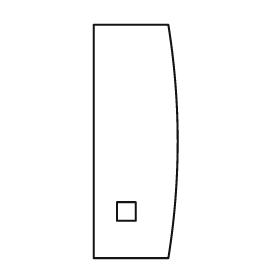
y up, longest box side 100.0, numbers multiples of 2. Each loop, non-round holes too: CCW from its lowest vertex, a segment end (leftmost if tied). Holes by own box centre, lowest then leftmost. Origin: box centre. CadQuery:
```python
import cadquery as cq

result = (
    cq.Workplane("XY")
    .moveTo(-18.0, -50.0)
    .lineTo(14.0, -50.0)
    .threePointArc((18.0, 0.0), (14.0, 50.0))
    .lineTo(-18.0, 50.0)
    .close()
    .moveTo(-8.0, -34.0)
    .lineTo(0.0, -34.0)
    .lineTo(0.0, -26.0)
    .lineTo(-8.0, -26.0)
    .close()
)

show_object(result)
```